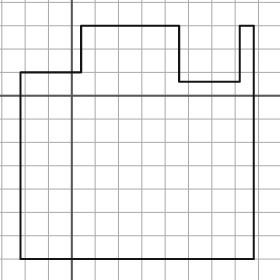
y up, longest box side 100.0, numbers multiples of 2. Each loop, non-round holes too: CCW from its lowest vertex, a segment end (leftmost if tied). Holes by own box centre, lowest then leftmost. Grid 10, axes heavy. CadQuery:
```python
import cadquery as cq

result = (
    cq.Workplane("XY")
    .moveTo(-22.0, -70.0)
    .lineTo(78.0, -70.0)
    .lineTo(78.0, 30.0)
    .lineTo(72.0, 30.0)
    .lineTo(72.0, 6.0)
    .lineTo(46.0, 6.0)
    .lineTo(46.0, 30.0)
    .lineTo(4.0, 30.0)
    .lineTo(4.0, 10.0)
    .lineTo(-22.0, 10.0)
    .close()
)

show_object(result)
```